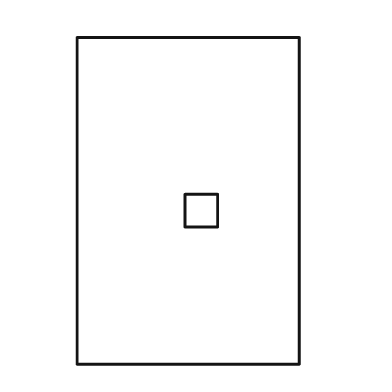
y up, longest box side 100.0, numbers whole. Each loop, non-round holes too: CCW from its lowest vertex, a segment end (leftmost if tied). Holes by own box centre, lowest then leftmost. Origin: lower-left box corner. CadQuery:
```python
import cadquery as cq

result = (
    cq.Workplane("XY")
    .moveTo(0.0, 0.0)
    .lineTo(68.0, 0.0)
    .lineTo(68.0, 100.0)
    .lineTo(0.0, 100.0)
    .close()
    .moveTo(33.0, 42.0)
    .lineTo(43.0, 42.0)
    .lineTo(43.0, 52.0)
    .lineTo(33.0, 52.0)
    .close()
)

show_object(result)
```